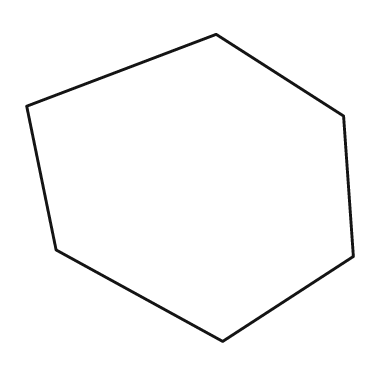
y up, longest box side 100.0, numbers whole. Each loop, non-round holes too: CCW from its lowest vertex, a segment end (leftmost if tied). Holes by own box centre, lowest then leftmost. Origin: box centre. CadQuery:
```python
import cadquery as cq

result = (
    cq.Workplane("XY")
    .moveTo(10.0, -47.0)
    .lineTo(50.0, -21.0)
    .lineTo(47.0, 22.0)
    .lineTo(8.0, 47.0)
    .lineTo(-50.0, 25.0)
    .lineTo(-41.0, -19.0)
    .close()
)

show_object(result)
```